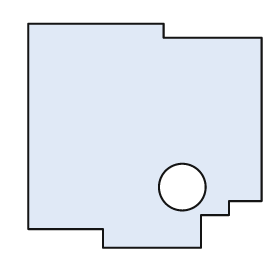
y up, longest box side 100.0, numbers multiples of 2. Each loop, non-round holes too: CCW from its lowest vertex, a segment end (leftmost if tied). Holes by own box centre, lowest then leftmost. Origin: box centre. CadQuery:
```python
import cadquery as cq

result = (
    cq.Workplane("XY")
    .moveTo(-18.0, -48.0)
    .lineTo(24.0, -48.0)
    .lineTo(24.0, -34.0)
    .lineTo(36.0, -34.0)
    .lineTo(36.0, -28.0)
    .lineTo(50.0, -28.0)
    .lineTo(50.0, 42.0)
    .lineTo(8.0, 42.0)
    .lineTo(8.0, 48.0)
    .lineTo(-50.0, 48.0)
    .lineTo(-50.0, -40.0)
    .lineTo(-18.0, -40.0)
    .close()
    .moveTo(16.0, -22.0)
    .circle(10.0)
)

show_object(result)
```